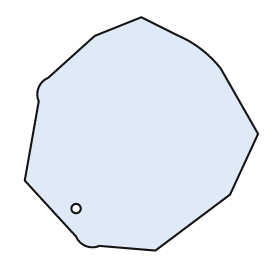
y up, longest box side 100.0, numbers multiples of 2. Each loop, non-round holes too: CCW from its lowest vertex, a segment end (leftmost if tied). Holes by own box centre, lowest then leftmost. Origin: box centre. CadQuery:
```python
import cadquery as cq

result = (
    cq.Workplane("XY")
    .moveTo(6.0, -50.0)
    .lineTo(38.0, -26.0)
    .lineTo(50.0, 0.0)
    .lineTo(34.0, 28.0)
    .threePointArc((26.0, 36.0), (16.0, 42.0))
    .lineTo(0.0, 50.0)
    .lineTo(-20.0, 42.0)
    .lineTo(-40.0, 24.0)
    .threePointArc((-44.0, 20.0), (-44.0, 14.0))
    .lineTo(-50.0, -20.0)
    .lineTo(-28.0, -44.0)
    .threePointArc((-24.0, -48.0), (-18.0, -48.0))
    .close()
    .moveTo(-28.0, -32.0)
    .circle(2.0)
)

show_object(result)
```